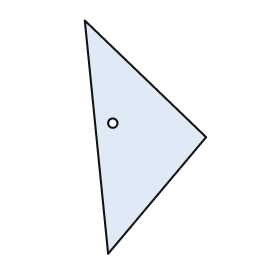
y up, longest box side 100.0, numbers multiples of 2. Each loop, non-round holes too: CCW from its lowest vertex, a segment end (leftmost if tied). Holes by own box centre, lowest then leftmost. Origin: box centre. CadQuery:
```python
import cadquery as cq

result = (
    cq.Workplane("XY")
    .moveTo(-16.0, -50.0)
    .lineTo(26.0, 0.0)
    .lineTo(-26.0, 50.0)
    .close()
    .moveTo(-14.0, 6.0)
    .circle(2.0)
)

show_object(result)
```